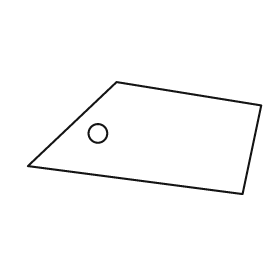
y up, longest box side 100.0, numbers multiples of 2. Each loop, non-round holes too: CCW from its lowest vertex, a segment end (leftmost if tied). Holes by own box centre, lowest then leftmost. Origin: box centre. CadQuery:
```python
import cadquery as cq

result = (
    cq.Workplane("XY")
    .moveTo(42.0, -24.0)
    .lineTo(50.0, 14.0)
    .lineTo(-12.0, 24.0)
    .lineTo(-50.0, -12.0)
    .close()
    .moveTo(-20.0, 2.0)
    .circle(4.0)
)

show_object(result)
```